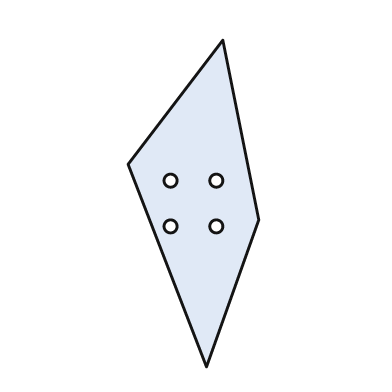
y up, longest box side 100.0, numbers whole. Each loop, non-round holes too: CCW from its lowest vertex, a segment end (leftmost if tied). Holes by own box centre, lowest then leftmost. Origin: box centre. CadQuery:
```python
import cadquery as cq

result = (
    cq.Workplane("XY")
    .moveTo(4.0, -50.0)
    .lineTo(20.0, -5.0)
    .lineTo(9.0, 50.0)
    .lineTo(-20.0, 12.0)
    .close()
    .moveTo(-7.0, -7.0)
    .circle(2.0)
    .moveTo(7.0, -7.0)
    .circle(2.0)
    .moveTo(-7.0, 7.0)
    .circle(2.0)
    .moveTo(7.0, 7.0)
    .circle(2.0)
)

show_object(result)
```